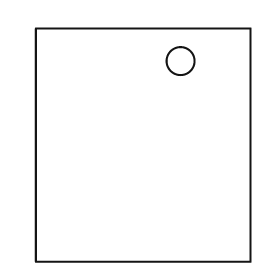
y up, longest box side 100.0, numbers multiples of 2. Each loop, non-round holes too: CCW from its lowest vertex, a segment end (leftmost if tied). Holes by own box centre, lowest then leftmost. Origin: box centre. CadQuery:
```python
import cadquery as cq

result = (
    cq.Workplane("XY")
    .moveTo(-46.0, -50.0)
    .lineTo(46.0, -50.0)
    .lineTo(46.0, 50.0)
    .lineTo(-46.0, 50.0)
    .close()
    .moveTo(16.0, 36.0)
    .circle(6.0)
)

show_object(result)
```